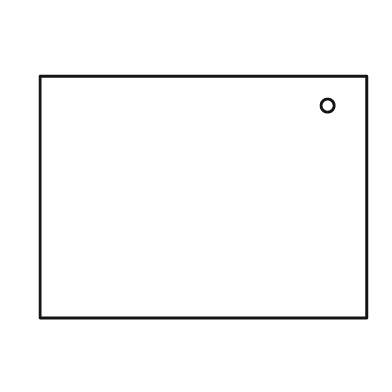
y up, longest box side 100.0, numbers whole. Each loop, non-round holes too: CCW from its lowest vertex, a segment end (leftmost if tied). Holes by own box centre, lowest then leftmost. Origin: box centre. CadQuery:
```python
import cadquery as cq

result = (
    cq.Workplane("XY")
    .moveTo(-50.0, -37.0)
    .lineTo(50.0, -37.0)
    .lineTo(50.0, 37.0)
    .lineTo(-50.0, 37.0)
    .close()
    .moveTo(38.0, 28.0)
    .circle(2.0)
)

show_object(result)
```